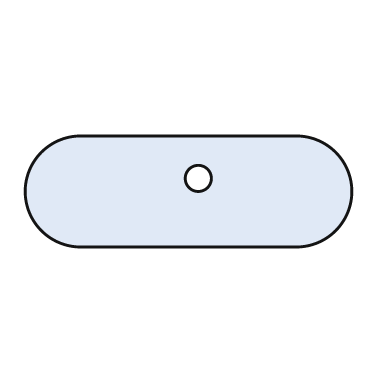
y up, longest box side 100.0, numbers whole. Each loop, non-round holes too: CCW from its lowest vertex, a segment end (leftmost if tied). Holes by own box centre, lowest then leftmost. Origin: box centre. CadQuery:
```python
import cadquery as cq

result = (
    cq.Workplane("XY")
    .moveTo(-33.0, -17.0)
    .lineTo(33.0, -17.0)
    .threePointArc((50.0, 0.0), (33.0, 17.0))
    .lineTo(-33.0, 17.0)
    .threePointArc((-50.0, 0.0), (-33.0, -17.0))
    .close()
    .moveTo(3.0, 4.0)
    .circle(4.0)
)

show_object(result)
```